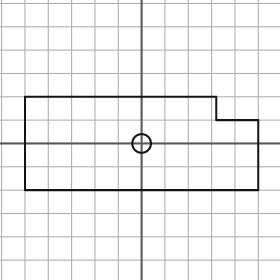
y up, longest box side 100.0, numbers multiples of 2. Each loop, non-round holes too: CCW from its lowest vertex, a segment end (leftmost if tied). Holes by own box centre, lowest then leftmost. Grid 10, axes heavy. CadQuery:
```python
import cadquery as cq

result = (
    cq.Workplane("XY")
    .moveTo(-50.0, -20.0)
    .lineTo(50.0, -20.0)
    .lineTo(50.0, 10.0)
    .lineTo(32.0, 10.0)
    .lineTo(32.0, 20.0)
    .lineTo(-50.0, 20.0)
    .close()
    .moveTo(0.0, 0.0)
    .circle(4.0)
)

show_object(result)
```